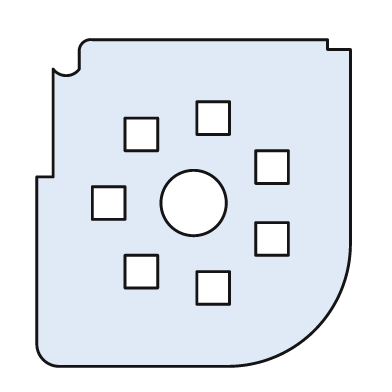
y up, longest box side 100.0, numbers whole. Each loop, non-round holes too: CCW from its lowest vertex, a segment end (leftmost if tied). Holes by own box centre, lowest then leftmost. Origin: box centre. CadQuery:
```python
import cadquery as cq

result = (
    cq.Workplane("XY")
    .moveTo(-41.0, -50.0)
    .lineTo(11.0, -50.0)
    .threePointArc((37.0, -39.0), (48.0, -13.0))
    .lineTo(48.0, 47.0)
    .lineTo(41.0, 47.0)
    .lineTo(41.0, 50.0)
    .lineTo(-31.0, 50.0)
    .threePointArc((-34.0, 49.0), (-35.0, 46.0))
    .lineTo(-35.0, 41.0)
    .threePointArc((-39.0, 39.0), (-43.0, 41.0))
    .lineTo(-43.0, 8.0)
    .lineTo(-48.0, 8.0)
    .lineTo(-48.0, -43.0)
    .threePointArc((-46.0, -48.0), (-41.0, -50.0))
    .close()
    .moveTo(1.0, -31.0)
    .lineTo(11.0, -31.0)
    .lineTo(11.0, -21.0)
    .lineTo(1.0, -21.0)
    .close()
    .moveTo(-21.0, -26.0)
    .lineTo(-11.0, -26.0)
    .lineTo(-11.0, -16.0)
    .lineTo(-21.0, -16.0)
    .close()
    .moveTo(19.0, -16.0)
    .lineTo(29.0, -16.0)
    .lineTo(29.0, -6.0)
    .lineTo(19.0, -6.0)
    .close()
    .moveTo(-31.0, -5.0)
    .lineTo(-21.0, -5.0)
    .lineTo(-21.0, 5.0)
    .lineTo(-31.0, 5.0)
    .close()
    .moveTo(0.0, 0.0)
    .circle(10.0)
    .moveTo(19.0, 6.0)
    .lineTo(29.0, 6.0)
    .lineTo(29.0, 16.0)
    .lineTo(19.0, 16.0)
    .close()
    .moveTo(-21.0, 16.0)
    .lineTo(-11.0, 16.0)
    .lineTo(-11.0, 26.0)
    .lineTo(-21.0, 26.0)
    .close()
    .moveTo(1.0, 21.0)
    .lineTo(11.0, 21.0)
    .lineTo(11.0, 31.0)
    .lineTo(1.0, 31.0)
    .close()
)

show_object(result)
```